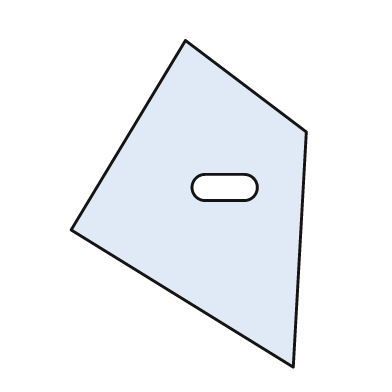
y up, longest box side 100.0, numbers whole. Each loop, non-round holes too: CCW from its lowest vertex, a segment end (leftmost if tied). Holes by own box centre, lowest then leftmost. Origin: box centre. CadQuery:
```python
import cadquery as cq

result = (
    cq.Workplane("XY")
    .moveTo(32.0, -50.0)
    .lineTo(36.0, 22.0)
    .lineTo(-1.0, 50.0)
    .lineTo(-36.0, -8.0)
    .close()
    .moveTo(5.0, 1.0)
    .lineTo(17.0, 1.0)
    .threePointArc((21.0, 5.0), (17.0, 9.0))
    .lineTo(5.0, 9.0)
    .threePointArc((1.0, 5.0), (5.0, 1.0))
    .close()
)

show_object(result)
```